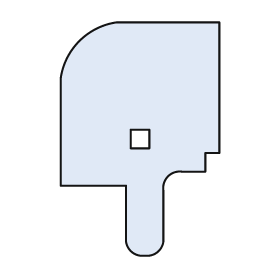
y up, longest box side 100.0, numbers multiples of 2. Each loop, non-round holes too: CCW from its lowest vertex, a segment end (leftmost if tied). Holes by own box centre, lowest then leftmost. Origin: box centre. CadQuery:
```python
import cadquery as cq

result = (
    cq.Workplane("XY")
    .moveTo(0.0, -50.0)
    .lineTo(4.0, -50.0)
    .threePointArc((8.0, -48.0), (10.0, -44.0))
    .lineTo(10.0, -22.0)
    .threePointArc((12.0, -16.0), (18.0, -14.0))
    .lineTo(28.0, -14.0)
    .lineTo(28.0, -6.0)
    .lineTo(34.0, -6.0)
    .lineTo(34.0, 50.0)
    .lineTo(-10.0, 50.0)
    .threePointArc((-26.0, 42.0), (-34.0, 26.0))
    .lineTo(-34.0, -20.0)
    .lineTo(-6.0, -20.0)
    .lineTo(-6.0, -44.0)
    .threePointArc((-4.0, -48.0), (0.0, -50.0))
    .close()
    .moveTo(-4.0, -4.0)
    .lineTo(4.0, -4.0)
    .lineTo(4.0, 4.0)
    .lineTo(-4.0, 4.0)
    .close()
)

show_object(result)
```